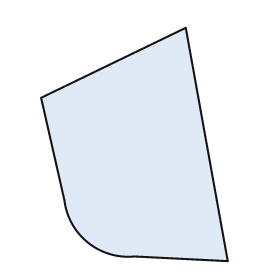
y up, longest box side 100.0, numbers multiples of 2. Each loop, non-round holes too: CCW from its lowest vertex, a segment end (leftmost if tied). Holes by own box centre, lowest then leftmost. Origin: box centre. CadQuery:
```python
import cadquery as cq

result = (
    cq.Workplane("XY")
    .moveTo(40.0, -50.0)
    .lineTo(22.0, 50.0)
    .lineTo(-40.0, 20.0)
    .lineTo(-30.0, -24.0)
    .threePointArc((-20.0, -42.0), (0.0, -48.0))
    .close()
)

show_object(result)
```